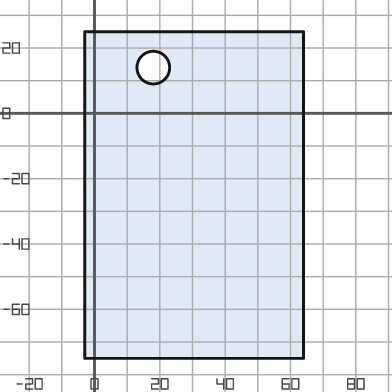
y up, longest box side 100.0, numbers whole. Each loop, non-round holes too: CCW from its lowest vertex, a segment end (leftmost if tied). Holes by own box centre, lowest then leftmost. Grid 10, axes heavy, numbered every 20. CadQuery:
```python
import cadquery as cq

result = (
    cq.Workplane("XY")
    .moveTo(-3.0, -75.0)
    .lineTo(64.0, -75.0)
    .lineTo(64.0, 25.0)
    .lineTo(-3.0, 25.0)
    .close()
    .moveTo(18.0, 14.0)
    .circle(5.0)
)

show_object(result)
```